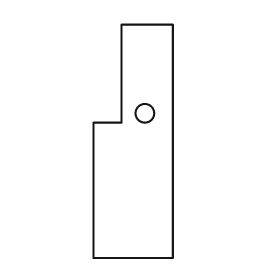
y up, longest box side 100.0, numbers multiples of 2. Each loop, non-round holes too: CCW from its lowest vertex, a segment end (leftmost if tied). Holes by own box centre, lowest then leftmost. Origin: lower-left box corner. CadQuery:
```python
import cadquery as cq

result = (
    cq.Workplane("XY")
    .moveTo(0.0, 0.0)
    .lineTo(34.0, 0.0)
    .lineTo(34.0, 100.0)
    .lineTo(12.0, 100.0)
    .lineTo(12.0, 58.0)
    .lineTo(0.0, 58.0)
    .close()
    .moveTo(22.0, 62.0)
    .circle(4.0)
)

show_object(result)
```